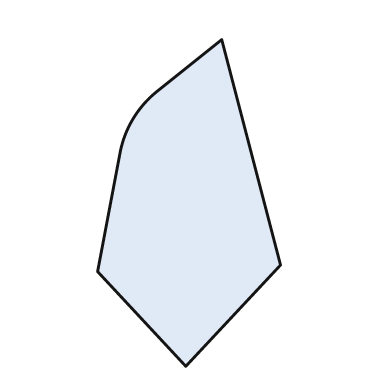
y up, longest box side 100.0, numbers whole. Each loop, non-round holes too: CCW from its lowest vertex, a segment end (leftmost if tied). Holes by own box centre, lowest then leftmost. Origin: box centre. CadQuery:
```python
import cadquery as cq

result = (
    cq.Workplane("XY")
    .moveTo(-1.0, -50.0)
    .lineTo(28.0, -19.0)
    .lineTo(10.0, 50.0)
    .lineTo(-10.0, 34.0)
    .threePointArc((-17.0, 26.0), (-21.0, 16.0))
    .lineTo(-28.0, -21.0)
    .close()
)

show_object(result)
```